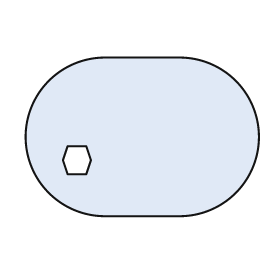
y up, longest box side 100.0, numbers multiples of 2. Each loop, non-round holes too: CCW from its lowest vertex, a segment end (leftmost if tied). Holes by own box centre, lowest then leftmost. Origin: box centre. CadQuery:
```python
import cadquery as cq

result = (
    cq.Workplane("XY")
    .moveTo(-16.0, -34.0)
    .lineTo(16.0, -34.0)
    .threePointArc((50.0, 0.0), (16.0, 34.0))
    .lineTo(-16.0, 34.0)
    .threePointArc((-50.0, 0.0), (-16.0, -34.0))
    .close()
    .moveTo(-32.0, -16.0)
    .lineTo(-24.0, -16.0)
    .lineTo(-22.0, -10.0)
    .lineTo(-24.0, -4.0)
    .lineTo(-32.0, -4.0)
    .lineTo(-34.0, -10.0)
    .close()
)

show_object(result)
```